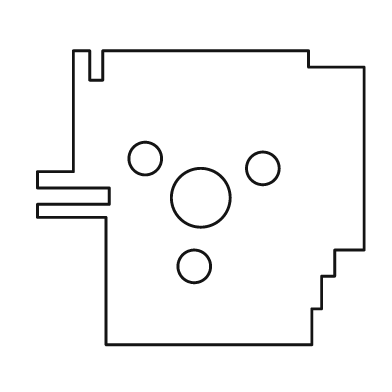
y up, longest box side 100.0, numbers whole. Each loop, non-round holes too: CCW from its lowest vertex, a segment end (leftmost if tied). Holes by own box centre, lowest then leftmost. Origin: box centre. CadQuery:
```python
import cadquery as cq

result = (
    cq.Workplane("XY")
    .moveTo(-29.0, -45.0)
    .lineTo(34.0, -45.0)
    .lineTo(34.0, -34.0)
    .lineTo(37.0, -34.0)
    .lineTo(37.0, -24.0)
    .lineTo(41.0, -24.0)
    .lineTo(41.0, -16.0)
    .lineTo(50.0, -16.0)
    .lineTo(50.0, 40.0)
    .lineTo(33.0, 40.0)
    .lineTo(33.0, 45.0)
    .lineTo(-30.0, 45.0)
    .lineTo(-30.0, 36.0)
    .lineTo(-34.0, 36.0)
    .lineTo(-34.0, 45.0)
    .lineTo(-39.0, 45.0)
    .lineTo(-39.0, 8.0)
    .lineTo(-50.0, 8.0)
    .lineTo(-50.0, 3.0)
    .lineTo(-28.0, 3.0)
    .lineTo(-28.0, -2.0)
    .lineTo(-50.0, -2.0)
    .lineTo(-50.0, -6.0)
    .lineTo(-29.0, -6.0)
    .close()
    .moveTo(-2.0, -21.0)
    .circle(5.0)
    .moveTo(0.0, 0.0)
    .circle(9.0)
    .moveTo(19.0, 9.0)
    .circle(5.0)
    .moveTo(-17.0, 12.0)
    .circle(5.0)
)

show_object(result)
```